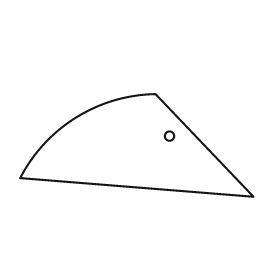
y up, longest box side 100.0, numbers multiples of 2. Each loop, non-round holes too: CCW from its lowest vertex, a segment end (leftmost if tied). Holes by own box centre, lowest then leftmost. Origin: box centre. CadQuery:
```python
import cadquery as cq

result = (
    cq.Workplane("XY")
    .moveTo(50.0, -22.0)
    .lineTo(8.0, 22.0)
    .threePointArc((-26.0, 12.0), (-50.0, -14.0))
    .close()
    .moveTo(14.0, 4.0)
    .circle(2.0)
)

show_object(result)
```